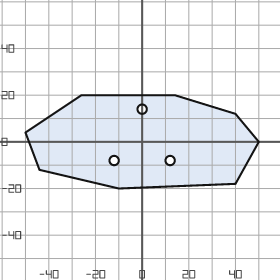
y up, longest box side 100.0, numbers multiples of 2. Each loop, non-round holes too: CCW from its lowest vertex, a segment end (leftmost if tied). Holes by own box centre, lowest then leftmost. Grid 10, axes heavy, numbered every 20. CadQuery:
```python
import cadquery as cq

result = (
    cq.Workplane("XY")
    .moveTo(-10.0, -20.0)
    .lineTo(40.0, -18.0)
    .lineTo(50.0, 0.0)
    .lineTo(40.0, 12.0)
    .lineTo(14.0, 20.0)
    .lineTo(-26.0, 20.0)
    .lineTo(-50.0, 4.0)
    .lineTo(-44.0, -12.0)
    .close()
    .moveTo(-12.0, -8.0)
    .circle(2.0)
    .moveTo(12.0, -8.0)
    .circle(2.0)
    .moveTo(0.0, 14.0)
    .circle(2.0)
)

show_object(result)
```